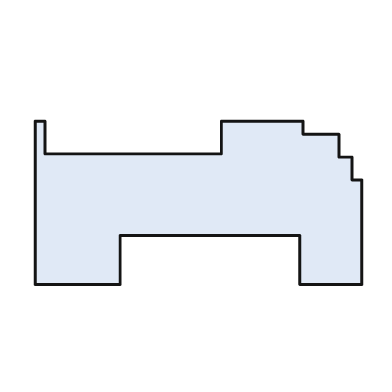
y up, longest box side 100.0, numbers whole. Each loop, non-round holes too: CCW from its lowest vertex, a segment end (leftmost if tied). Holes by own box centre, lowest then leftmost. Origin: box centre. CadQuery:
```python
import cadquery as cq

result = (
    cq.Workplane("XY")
    .moveTo(-50.0, -25.0)
    .lineTo(-24.0, -25.0)
    .lineTo(-24.0, -10.0)
    .lineTo(31.0, -10.0)
    .lineTo(31.0, -25.0)
    .lineTo(50.0, -25.0)
    .lineTo(50.0, 7.0)
    .lineTo(47.0, 7.0)
    .lineTo(47.0, 14.0)
    .lineTo(43.0, 14.0)
    .lineTo(43.0, 21.0)
    .lineTo(32.0, 21.0)
    .lineTo(32.0, 25.0)
    .lineTo(7.0, 25.0)
    .lineTo(7.0, 15.0)
    .lineTo(-47.0, 15.0)
    .lineTo(-47.0, 25.0)
    .lineTo(-50.0, 25.0)
    .close()
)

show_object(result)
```